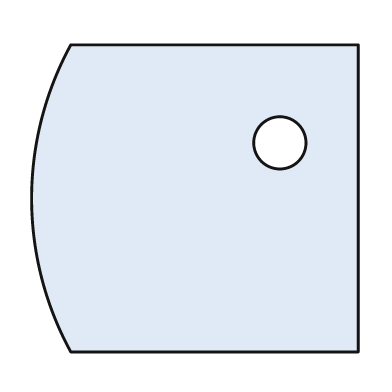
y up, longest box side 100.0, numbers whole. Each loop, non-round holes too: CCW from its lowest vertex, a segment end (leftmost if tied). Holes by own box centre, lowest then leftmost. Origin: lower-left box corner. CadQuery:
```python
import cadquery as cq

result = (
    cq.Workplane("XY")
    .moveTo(12.0, 0.0)
    .lineTo(100.0, 0.0)
    .lineTo(100.0, 94.0)
    .lineTo(12.0, 94.0)
    .threePointArc((0.0, 47.0), (12.0, 0.0))
    .close()
    .moveTo(76.0, 64.0)
    .circle(8.0)
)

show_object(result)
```